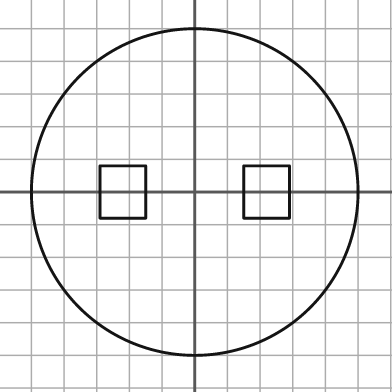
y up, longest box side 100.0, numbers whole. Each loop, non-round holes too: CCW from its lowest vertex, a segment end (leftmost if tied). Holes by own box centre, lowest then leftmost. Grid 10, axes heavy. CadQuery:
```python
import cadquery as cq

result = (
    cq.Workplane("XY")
    .moveTo(0.0, 0.0)
    .circle(50.0)
    .moveTo(-29.0, -8.0)
    .lineTo(-15.0, -8.0)
    .lineTo(-15.0, 8.0)
    .lineTo(-29.0, 8.0)
    .close()
    .moveTo(15.0, -8.0)
    .lineTo(29.0, -8.0)
    .lineTo(29.0, 8.0)
    .lineTo(15.0, 8.0)
    .close()
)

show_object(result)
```